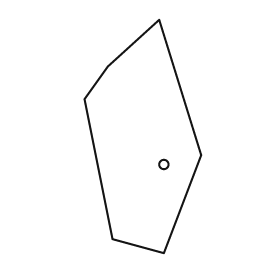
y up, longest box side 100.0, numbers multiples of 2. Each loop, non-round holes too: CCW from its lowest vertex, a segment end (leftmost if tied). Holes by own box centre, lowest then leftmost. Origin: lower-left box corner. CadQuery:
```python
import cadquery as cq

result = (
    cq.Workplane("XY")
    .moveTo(34.0, 0.0)
    .lineTo(50.0, 42.0)
    .lineTo(32.0, 100.0)
    .lineTo(10.0, 80.0)
    .lineTo(0.0, 66.0)
    .lineTo(12.0, 6.0)
    .close()
    .moveTo(34.0, 38.0)
    .circle(2.0)
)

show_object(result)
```